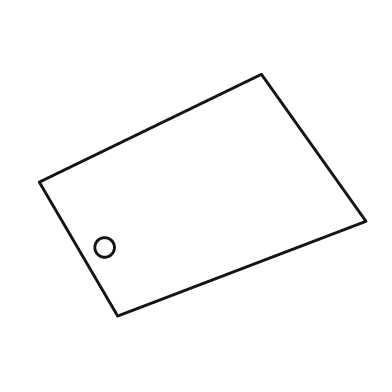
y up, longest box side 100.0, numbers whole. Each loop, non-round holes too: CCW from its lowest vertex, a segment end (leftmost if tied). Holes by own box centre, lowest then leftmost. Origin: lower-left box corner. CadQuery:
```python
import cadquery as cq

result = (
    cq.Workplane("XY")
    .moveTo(24.0, 0.0)
    .lineTo(100.0, 29.0)
    .lineTo(68.0, 74.0)
    .lineTo(0.0, 41.0)
    .close()
    .moveTo(20.0, 21.0)
    .circle(3.0)
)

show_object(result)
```